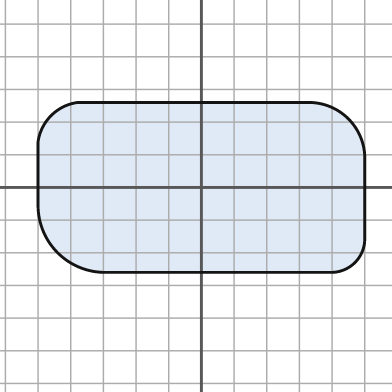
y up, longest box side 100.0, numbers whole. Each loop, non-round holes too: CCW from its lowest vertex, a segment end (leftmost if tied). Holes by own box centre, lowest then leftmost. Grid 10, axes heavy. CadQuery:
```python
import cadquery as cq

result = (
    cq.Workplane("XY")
    .moveTo(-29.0, -26.0)
    .lineTo(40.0, -26.0)
    .threePointArc((47.0, -23.0), (50.0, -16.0))
    .lineTo(50.0, 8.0)
    .threePointArc((45.0, 21.0), (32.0, 26.0))
    .lineTo(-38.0, 26.0)
    .threePointArc((-46.0, 22.0), (-50.0, 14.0))
    .lineTo(-50.0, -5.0)
    .threePointArc((-44.0, -20.0), (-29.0, -26.0))
    .close()
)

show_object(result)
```